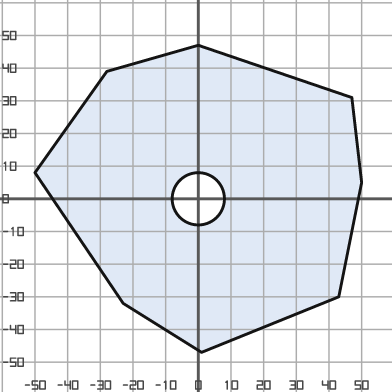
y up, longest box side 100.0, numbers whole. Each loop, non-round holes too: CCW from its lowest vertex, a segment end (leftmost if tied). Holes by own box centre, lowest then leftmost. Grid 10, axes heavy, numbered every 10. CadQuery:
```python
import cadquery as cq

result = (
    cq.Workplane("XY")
    .moveTo(1.0, -47.0)
    .lineTo(43.0, -30.0)
    .lineTo(50.0, 5.0)
    .lineTo(47.0, 31.0)
    .lineTo(0.0, 47.0)
    .lineTo(-28.0, 39.0)
    .lineTo(-50.0, 8.0)
    .lineTo(-23.0, -32.0)
    .close()
    .moveTo(0.0, 0.0)
    .circle(8.0)
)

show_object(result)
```